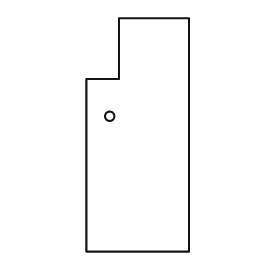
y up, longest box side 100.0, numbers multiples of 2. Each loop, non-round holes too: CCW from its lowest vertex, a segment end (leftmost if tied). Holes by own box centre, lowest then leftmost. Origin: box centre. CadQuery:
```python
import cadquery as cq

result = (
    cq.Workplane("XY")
    .moveTo(-22.0, -50.0)
    .lineTo(22.0, -50.0)
    .lineTo(22.0, 50.0)
    .lineTo(-8.0, 50.0)
    .lineTo(-8.0, 24.0)
    .lineTo(-22.0, 24.0)
    .close()
    .moveTo(-12.0, 8.0)
    .circle(2.0)
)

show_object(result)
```